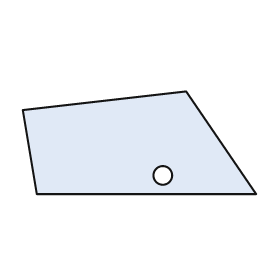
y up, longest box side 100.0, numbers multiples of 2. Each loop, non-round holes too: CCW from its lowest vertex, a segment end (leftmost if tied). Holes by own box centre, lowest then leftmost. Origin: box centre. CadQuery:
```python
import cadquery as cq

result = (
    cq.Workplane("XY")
    .moveTo(-44.0, -22.0)
    .lineTo(50.0, -22.0)
    .lineTo(20.0, 22.0)
    .lineTo(-50.0, 14.0)
    .close()
    .moveTo(10.0, -14.0)
    .circle(4.0)
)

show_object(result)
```